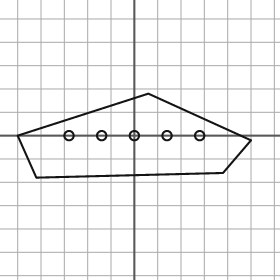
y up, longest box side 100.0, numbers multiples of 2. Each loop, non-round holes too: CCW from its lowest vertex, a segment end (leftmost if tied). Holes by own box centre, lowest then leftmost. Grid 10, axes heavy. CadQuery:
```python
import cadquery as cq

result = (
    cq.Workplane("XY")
    .moveTo(-42.0, -18.0)
    .lineTo(38.0, -16.0)
    .lineTo(50.0, -2.0)
    .lineTo(6.0, 18.0)
    .lineTo(-50.0, 0.0)
    .close()
    .moveTo(-28.0, 0.0)
    .circle(2.0)
    .moveTo(-14.0, 0.0)
    .circle(2.0)
    .moveTo(0.0, 0.0)
    .circle(2.0)
    .moveTo(14.0, 0.0)
    .circle(2.0)
    .moveTo(28.0, 0.0)
    .circle(2.0)
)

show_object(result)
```